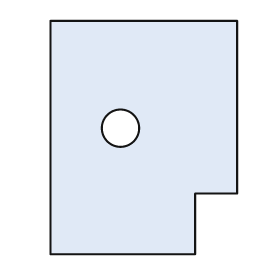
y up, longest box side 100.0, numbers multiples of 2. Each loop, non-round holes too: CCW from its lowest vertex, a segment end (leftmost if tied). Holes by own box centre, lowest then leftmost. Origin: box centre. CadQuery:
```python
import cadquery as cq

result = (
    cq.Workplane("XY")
    .moveTo(-40.0, -50.0)
    .lineTo(22.0, -50.0)
    .lineTo(22.0, -24.0)
    .lineTo(40.0, -24.0)
    .lineTo(40.0, 50.0)
    .lineTo(-40.0, 50.0)
    .close()
    .moveTo(-10.0, 4.0)
    .circle(8.0)
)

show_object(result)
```